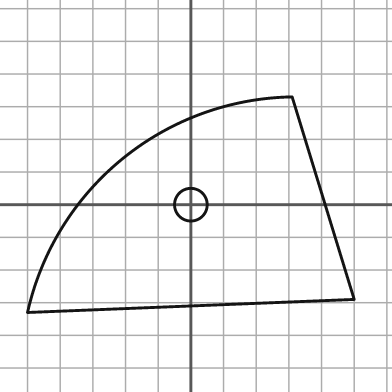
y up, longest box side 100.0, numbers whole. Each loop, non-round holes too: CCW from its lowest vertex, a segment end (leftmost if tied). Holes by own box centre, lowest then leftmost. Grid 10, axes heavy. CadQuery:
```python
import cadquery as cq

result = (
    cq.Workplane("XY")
    .moveTo(-50.0, -33.0)
    .lineTo(50.0, -29.0)
    .lineTo(31.0, 33.0)
    .threePointArc((-21.0, 14.0), (-50.0, -33.0))
    .close()
    .moveTo(0.0, 0.0)
    .circle(5.0)
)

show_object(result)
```